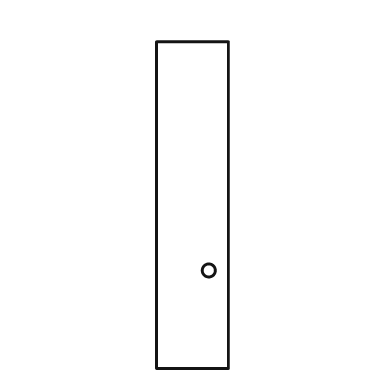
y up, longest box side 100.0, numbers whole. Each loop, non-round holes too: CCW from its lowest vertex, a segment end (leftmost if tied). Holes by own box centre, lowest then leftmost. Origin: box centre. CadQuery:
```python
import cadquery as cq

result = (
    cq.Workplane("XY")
    .moveTo(-11.0, -50.0)
    .lineTo(11.0, -50.0)
    .lineTo(11.0, 50.0)
    .lineTo(-11.0, 50.0)
    .close()
    .moveTo(5.0, -20.0)
    .circle(2.0)
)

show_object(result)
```